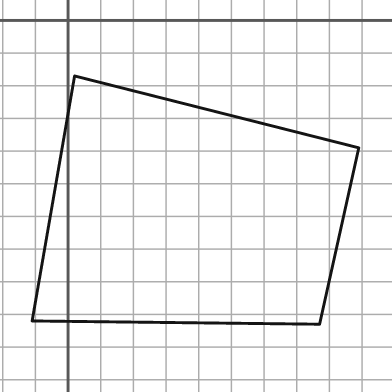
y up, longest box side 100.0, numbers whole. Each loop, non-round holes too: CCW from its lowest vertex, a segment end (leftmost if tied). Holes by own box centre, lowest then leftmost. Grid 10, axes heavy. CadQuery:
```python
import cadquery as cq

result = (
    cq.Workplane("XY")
    .moveTo(77.0, -93.0)
    .lineTo(89.0, -39.0)
    .lineTo(2.0, -17.0)
    .lineTo(-11.0, -92.0)
    .close()
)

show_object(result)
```